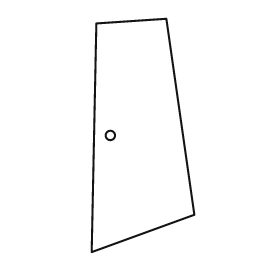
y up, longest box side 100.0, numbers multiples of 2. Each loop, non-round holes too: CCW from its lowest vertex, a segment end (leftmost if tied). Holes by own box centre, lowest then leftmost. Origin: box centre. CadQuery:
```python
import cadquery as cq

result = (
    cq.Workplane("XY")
    .moveTo(-22.0, -50.0)
    .lineTo(22.0, -34.0)
    .lineTo(10.0, 50.0)
    .lineTo(-20.0, 48.0)
    .close()
    .moveTo(-14.0, 0.0)
    .circle(2.0)
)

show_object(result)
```